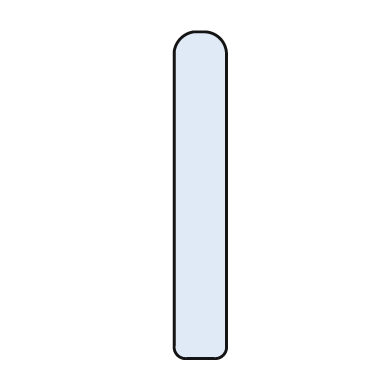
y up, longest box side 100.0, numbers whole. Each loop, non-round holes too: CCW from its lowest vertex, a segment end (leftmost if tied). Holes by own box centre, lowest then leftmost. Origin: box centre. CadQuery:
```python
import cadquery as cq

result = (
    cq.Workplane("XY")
    .moveTo(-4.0, -50.0)
    .lineTo(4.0, -50.0)
    .threePointArc((7.0, -49.0), (8.0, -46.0))
    .lineTo(8.0, 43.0)
    .threePointArc((6.0, 48.0), (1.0, 50.0))
    .lineTo(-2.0, 50.0)
    .threePointArc((-6.0, 48.0), (-8.0, 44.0))
    .lineTo(-8.0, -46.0)
    .threePointArc((-7.0, -49.0), (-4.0, -50.0))
    .close()
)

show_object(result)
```